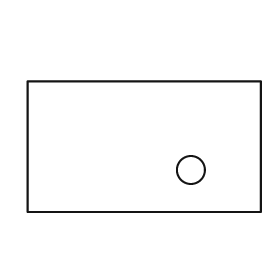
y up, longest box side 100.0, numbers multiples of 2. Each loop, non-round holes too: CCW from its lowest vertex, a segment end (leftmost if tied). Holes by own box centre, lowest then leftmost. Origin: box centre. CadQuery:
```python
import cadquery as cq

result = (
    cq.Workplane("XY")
    .moveTo(-50.0, -28.0)
    .lineTo(50.0, -28.0)
    .lineTo(50.0, 28.0)
    .lineTo(-50.0, 28.0)
    .close()
    .moveTo(20.0, -10.0)
    .circle(6.0)
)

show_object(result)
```